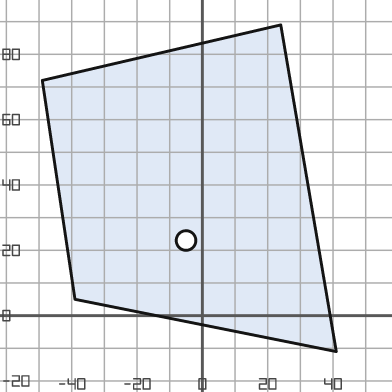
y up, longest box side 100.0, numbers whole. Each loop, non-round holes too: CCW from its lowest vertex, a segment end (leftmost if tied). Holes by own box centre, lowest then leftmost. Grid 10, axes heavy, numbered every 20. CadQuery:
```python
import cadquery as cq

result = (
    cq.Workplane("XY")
    .moveTo(41.0, -11.0)
    .lineTo(24.0, 89.0)
    .lineTo(-49.0, 72.0)
    .lineTo(-39.0, 5.0)
    .close()
    .moveTo(-5.0, 23.0)
    .circle(3.0)
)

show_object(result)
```